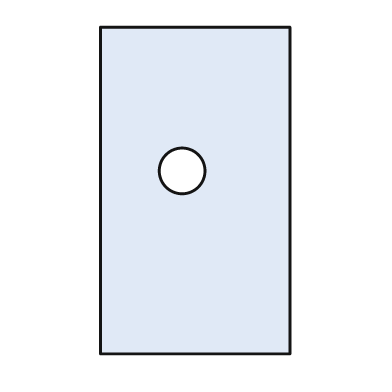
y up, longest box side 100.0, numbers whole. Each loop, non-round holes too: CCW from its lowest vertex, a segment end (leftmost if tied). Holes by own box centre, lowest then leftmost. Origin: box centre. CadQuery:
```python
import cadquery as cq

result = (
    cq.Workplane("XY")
    .moveTo(-29.0, -50.0)
    .lineTo(29.0, -50.0)
    .lineTo(29.0, 50.0)
    .lineTo(-29.0, 50.0)
    .close()
    .moveTo(-4.0, 6.0)
    .circle(7.0)
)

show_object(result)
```